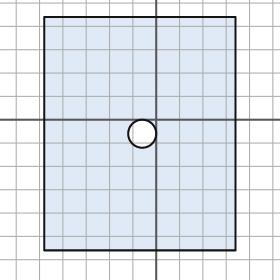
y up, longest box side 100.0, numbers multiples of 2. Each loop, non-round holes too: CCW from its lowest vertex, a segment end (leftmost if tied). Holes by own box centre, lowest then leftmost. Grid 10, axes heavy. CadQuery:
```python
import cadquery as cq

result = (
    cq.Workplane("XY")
    .moveTo(-48.0, -56.0)
    .lineTo(34.0, -56.0)
    .lineTo(34.0, 44.0)
    .lineTo(-48.0, 44.0)
    .close()
    .moveTo(-6.0, -6.0)
    .circle(6.0)
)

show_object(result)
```